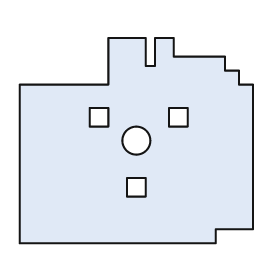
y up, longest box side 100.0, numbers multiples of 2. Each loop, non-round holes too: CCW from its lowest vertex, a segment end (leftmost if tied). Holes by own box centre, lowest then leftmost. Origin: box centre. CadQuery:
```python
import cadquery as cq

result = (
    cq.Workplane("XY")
    .moveTo(-50.0, -44.0)
    .lineTo(34.0, -44.0)
    .lineTo(34.0, -38.0)
    .lineTo(50.0, -38.0)
    .lineTo(50.0, 24.0)
    .lineTo(44.0, 24.0)
    .lineTo(44.0, 30.0)
    .lineTo(38.0, 30.0)
    .lineTo(38.0, 36.0)
    .lineTo(16.0, 36.0)
    .lineTo(16.0, 44.0)
    .lineTo(8.0, 44.0)
    .lineTo(8.0, 32.0)
    .lineTo(4.0, 32.0)
    .lineTo(4.0, 44.0)
    .lineTo(-12.0, 44.0)
    .lineTo(-12.0, 24.0)
    .lineTo(-50.0, 24.0)
    .close()
    .moveTo(-4.0, -24.0)
    .lineTo(4.0, -24.0)
    .lineTo(4.0, -16.0)
    .lineTo(-4.0, -16.0)
    .close()
    .moveTo(0.0, 0.0)
    .circle(6.0)
    .moveTo(-20.0, 6.0)
    .lineTo(-12.0, 6.0)
    .lineTo(-12.0, 14.0)
    .lineTo(-20.0, 14.0)
    .close()
    .moveTo(14.0, 6.0)
    .lineTo(22.0, 6.0)
    .lineTo(22.0, 14.0)
    .lineTo(14.0, 14.0)
    .close()
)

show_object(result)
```